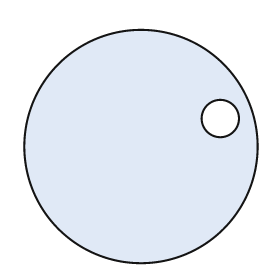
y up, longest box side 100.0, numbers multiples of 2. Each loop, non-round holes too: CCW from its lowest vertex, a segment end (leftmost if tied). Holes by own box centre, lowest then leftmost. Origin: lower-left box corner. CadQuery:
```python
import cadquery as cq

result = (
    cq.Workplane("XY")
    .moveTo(50.0, 50.0)
    .circle(50.0)
    .moveTo(84.0, 62.0)
    .circle(8.0)
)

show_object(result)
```